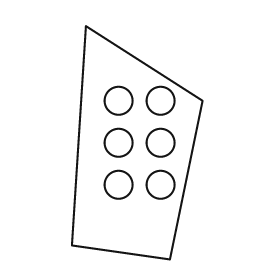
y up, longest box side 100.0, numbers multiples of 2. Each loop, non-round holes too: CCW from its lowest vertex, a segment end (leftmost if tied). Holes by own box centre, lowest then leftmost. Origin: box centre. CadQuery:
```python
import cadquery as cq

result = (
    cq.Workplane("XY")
    .moveTo(14.0, -50.0)
    .lineTo(28.0, 18.0)
    .lineTo(-22.0, 50.0)
    .lineTo(-28.0, -44.0)
    .close()
    .moveTo(-8.0, -18.0)
    .circle(6.0)
    .moveTo(10.0, -18.0)
    .circle(6.0)
    .moveTo(-8.0, 0.0)
    .circle(6.0)
    .moveTo(10.0, 0.0)
    .circle(6.0)
    .moveTo(-8.0, 18.0)
    .circle(6.0)
    .moveTo(10.0, 18.0)
    .circle(6.0)
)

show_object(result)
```